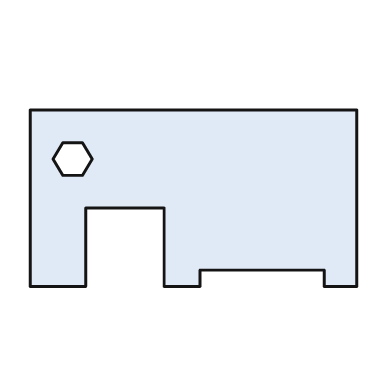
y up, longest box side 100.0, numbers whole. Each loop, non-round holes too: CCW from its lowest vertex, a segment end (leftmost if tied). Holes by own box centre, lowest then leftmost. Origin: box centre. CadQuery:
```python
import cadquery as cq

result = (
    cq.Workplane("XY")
    .moveTo(-50.0, -27.0)
    .lineTo(-33.0, -27.0)
    .lineTo(-33.0, -3.0)
    .lineTo(-9.0, -3.0)
    .lineTo(-9.0, -27.0)
    .lineTo(2.0, -27.0)
    .lineTo(2.0, -22.0)
    .lineTo(40.0, -22.0)
    .lineTo(40.0, -27.0)
    .lineTo(50.0, -27.0)
    .lineTo(50.0, 27.0)
    .lineTo(-50.0, 27.0)
    .close()
    .moveTo(-40.0, 7.0)
    .lineTo(-34.0, 7.0)
    .lineTo(-31.0, 12.0)
    .lineTo(-34.0, 17.0)
    .lineTo(-40.0, 17.0)
    .lineTo(-43.0, 12.0)
    .close()
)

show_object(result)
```